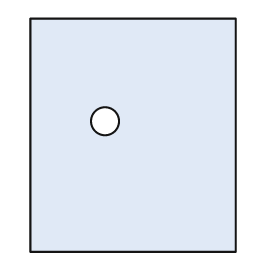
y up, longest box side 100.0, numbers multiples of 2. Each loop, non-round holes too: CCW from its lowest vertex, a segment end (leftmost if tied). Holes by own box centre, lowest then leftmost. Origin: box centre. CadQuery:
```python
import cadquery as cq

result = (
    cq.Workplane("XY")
    .moveTo(-44.0, -50.0)
    .lineTo(44.0, -50.0)
    .lineTo(44.0, 50.0)
    .lineTo(-44.0, 50.0)
    .close()
    .moveTo(-12.0, 6.0)
    .circle(6.0)
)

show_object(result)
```